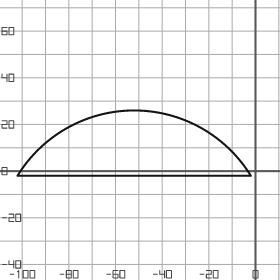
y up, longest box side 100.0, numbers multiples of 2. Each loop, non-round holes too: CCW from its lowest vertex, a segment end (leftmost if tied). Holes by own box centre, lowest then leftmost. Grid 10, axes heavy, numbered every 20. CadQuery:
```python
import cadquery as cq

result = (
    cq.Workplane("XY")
    .moveTo(-102.0, -2.0)
    .lineTo(-2.0, -2.0)
    .threePointArc((-52.0, 26.0), (-102.0, -2.0))
    .close()
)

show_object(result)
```